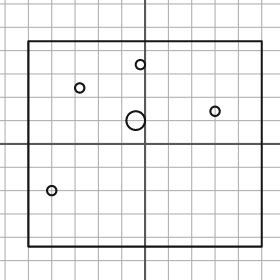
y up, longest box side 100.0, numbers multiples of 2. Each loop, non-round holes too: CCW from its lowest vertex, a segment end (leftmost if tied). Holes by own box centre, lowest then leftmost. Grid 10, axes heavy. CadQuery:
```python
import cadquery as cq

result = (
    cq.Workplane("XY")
    .moveTo(-50.0, -44.0)
    .lineTo(50.0, -44.0)
    .lineTo(50.0, 44.0)
    .lineTo(-50.0, 44.0)
    .close()
    .moveTo(-40.0, -20.0)
    .circle(2.0)
    .moveTo(-4.0, 10.0)
    .circle(4.0)
    .moveTo(30.0, 14.0)
    .circle(2.0)
    .moveTo(-28.0, 24.0)
    .circle(2.0)
    .moveTo(-2.0, 34.0)
    .circle(2.0)
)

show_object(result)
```